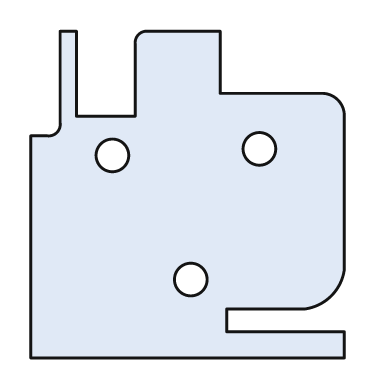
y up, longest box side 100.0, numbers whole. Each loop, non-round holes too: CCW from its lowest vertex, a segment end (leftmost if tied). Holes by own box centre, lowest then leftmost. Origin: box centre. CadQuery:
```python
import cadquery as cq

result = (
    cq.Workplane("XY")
    .moveTo(-48.0, -50.0)
    .lineTo(48.0, -50.0)
    .lineTo(48.0, -42.0)
    .lineTo(12.0, -42.0)
    .lineTo(12.0, -35.0)
    .lineTo(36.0, -35.0)
    .threePointArc((44.0, -31.0), (48.0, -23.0))
    .lineTo(48.0, 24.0)
    .threePointArc((46.0, 29.0), (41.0, 31.0))
    .lineTo(10.0, 31.0)
    .lineTo(10.0, 50.0)
    .lineTo(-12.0, 50.0)
    .threePointArc((-15.0, 49.0), (-16.0, 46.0))
    .lineTo(-16.0, 24.0)
    .lineTo(-34.0, 24.0)
    .lineTo(-34.0, 50.0)
    .lineTo(-39.0, 50.0)
    .lineTo(-39.0, 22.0)
    .threePointArc((-40.0, 19.0), (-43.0, 18.0))
    .lineTo(-48.0, 18.0)
    .close()
    .moveTo(1.0, -26.0)
    .circle(5.0)
    .moveTo(-23.0, 12.0)
    .circle(5.0)
    .moveTo(22.0, 14.0)
    .circle(5.0)
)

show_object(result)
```